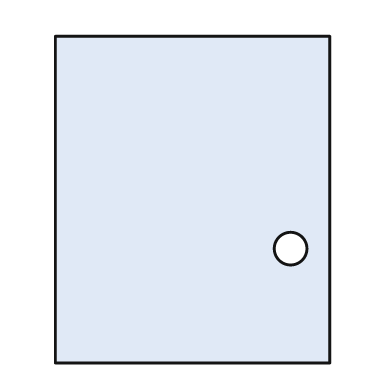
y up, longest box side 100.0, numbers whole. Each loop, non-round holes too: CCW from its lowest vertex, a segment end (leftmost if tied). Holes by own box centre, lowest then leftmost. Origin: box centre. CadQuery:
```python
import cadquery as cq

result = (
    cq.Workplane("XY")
    .moveTo(-42.0, -50.0)
    .lineTo(42.0, -50.0)
    .lineTo(42.0, 50.0)
    .lineTo(-42.0, 50.0)
    .close()
    .moveTo(30.0, -15.0)
    .circle(5.0)
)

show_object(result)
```